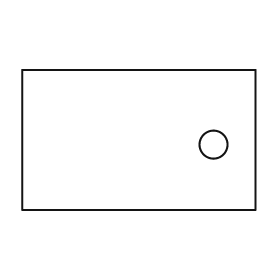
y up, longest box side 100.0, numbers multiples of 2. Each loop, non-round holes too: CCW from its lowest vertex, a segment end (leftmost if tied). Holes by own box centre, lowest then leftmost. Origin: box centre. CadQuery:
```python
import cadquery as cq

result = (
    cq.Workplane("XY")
    .moveTo(-50.0, -30.0)
    .lineTo(50.0, -30.0)
    .lineTo(50.0, 30.0)
    .lineTo(-50.0, 30.0)
    .close()
    .moveTo(32.0, -2.0)
    .circle(6.0)
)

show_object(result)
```